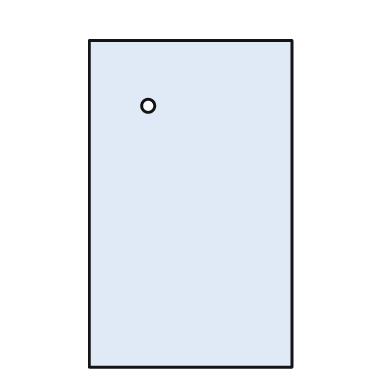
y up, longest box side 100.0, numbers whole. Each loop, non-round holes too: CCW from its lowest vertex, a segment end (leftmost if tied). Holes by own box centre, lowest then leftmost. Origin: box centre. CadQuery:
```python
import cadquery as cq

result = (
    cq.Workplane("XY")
    .moveTo(-31.0, -50.0)
    .lineTo(31.0, -50.0)
    .lineTo(31.0, 50.0)
    .lineTo(-31.0, 50.0)
    .close()
    .moveTo(-13.0, 30.0)
    .circle(2.0)
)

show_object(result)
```